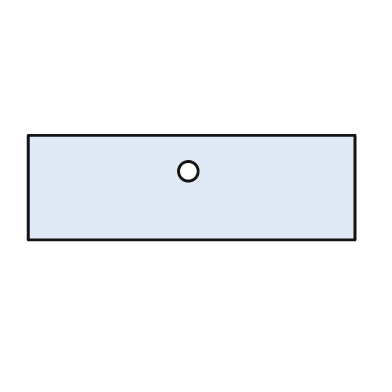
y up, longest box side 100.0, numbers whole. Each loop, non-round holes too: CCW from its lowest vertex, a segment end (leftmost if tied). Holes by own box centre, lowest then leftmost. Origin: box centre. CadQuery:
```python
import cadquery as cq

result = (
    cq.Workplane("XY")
    .moveTo(-50.0, -16.0)
    .lineTo(50.0, -16.0)
    .lineTo(50.0, 16.0)
    .lineTo(-50.0, 16.0)
    .close()
    .moveTo(-1.0, 5.0)
    .circle(3.0)
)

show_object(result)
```